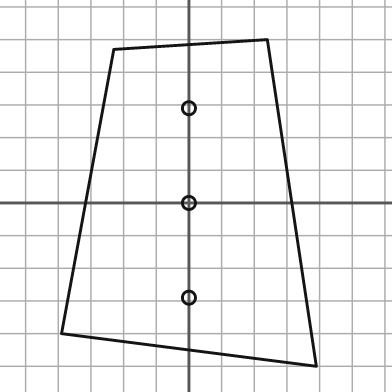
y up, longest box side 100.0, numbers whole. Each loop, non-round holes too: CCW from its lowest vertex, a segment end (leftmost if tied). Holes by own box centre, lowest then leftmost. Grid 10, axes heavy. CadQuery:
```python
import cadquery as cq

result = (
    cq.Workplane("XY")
    .moveTo(39.0, -50.0)
    .lineTo(24.0, 50.0)
    .lineTo(-23.0, 47.0)
    .lineTo(-39.0, -40.0)
    .close()
    .moveTo(0.0, -29.0)
    .circle(2.0)
    .moveTo(0.0, 0.0)
    .circle(2.0)
    .moveTo(0.0, 29.0)
    .circle(2.0)
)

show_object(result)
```